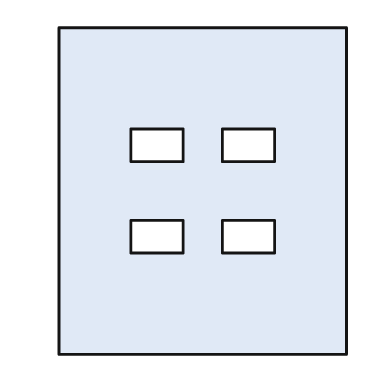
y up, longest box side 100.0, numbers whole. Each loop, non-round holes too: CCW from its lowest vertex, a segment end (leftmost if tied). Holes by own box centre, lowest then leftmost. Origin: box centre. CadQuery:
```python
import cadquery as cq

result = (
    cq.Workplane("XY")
    .moveTo(-44.0, -50.0)
    .lineTo(44.0, -50.0)
    .lineTo(44.0, 50.0)
    .lineTo(-44.0, 50.0)
    .close()
    .moveTo(-22.0, -19.0)
    .lineTo(-6.0, -19.0)
    .lineTo(-6.0, -9.0)
    .lineTo(-22.0, -9.0)
    .close()
    .moveTo(6.0, -19.0)
    .lineTo(22.0, -19.0)
    .lineTo(22.0, -9.0)
    .lineTo(6.0, -9.0)
    .close()
    .moveTo(-22.0, 9.0)
    .lineTo(-6.0, 9.0)
    .lineTo(-6.0, 19.0)
    .lineTo(-22.0, 19.0)
    .close()
    .moveTo(6.0, 9.0)
    .lineTo(22.0, 9.0)
    .lineTo(22.0, 19.0)
    .lineTo(6.0, 19.0)
    .close()
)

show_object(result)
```